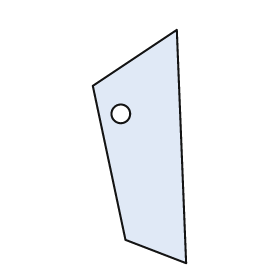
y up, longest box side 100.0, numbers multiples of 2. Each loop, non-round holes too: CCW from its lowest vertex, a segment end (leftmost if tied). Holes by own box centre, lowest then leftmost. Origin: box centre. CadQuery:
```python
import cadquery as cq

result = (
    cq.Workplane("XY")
    .moveTo(20.0, -50.0)
    .lineTo(16.0, 50.0)
    .lineTo(-20.0, 26.0)
    .lineTo(-6.0, -40.0)
    .close()
    .moveTo(-8.0, 14.0)
    .circle(4.0)
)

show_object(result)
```